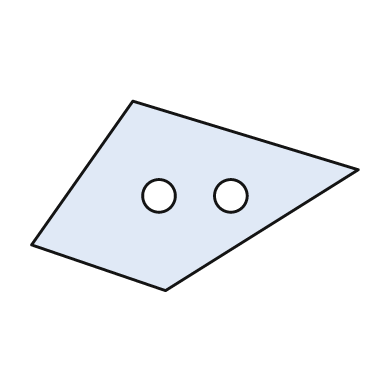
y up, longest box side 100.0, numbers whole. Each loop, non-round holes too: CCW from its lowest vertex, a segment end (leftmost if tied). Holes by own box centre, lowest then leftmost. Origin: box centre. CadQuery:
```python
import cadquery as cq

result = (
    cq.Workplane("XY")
    .moveTo(-9.0, -29.0)
    .lineTo(50.0, 8.0)
    .lineTo(-19.0, 29.0)
    .lineTo(-50.0, -15.0)
    .close()
    .moveTo(-11.0, 0.0)
    .circle(5.0)
    .moveTo(11.0, 0.0)
    .circle(5.0)
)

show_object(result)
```